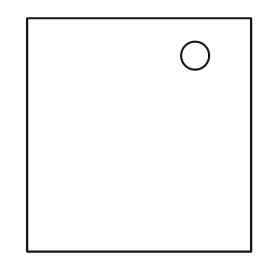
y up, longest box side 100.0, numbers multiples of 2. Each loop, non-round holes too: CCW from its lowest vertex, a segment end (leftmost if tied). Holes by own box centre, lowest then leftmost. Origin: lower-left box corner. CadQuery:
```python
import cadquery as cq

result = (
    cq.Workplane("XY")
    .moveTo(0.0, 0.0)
    .lineTo(96.0, 0.0)
    .lineTo(96.0, 100.0)
    .lineTo(0.0, 100.0)
    .close()
    .moveTo(72.0, 84.0)
    .circle(6.0)
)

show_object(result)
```